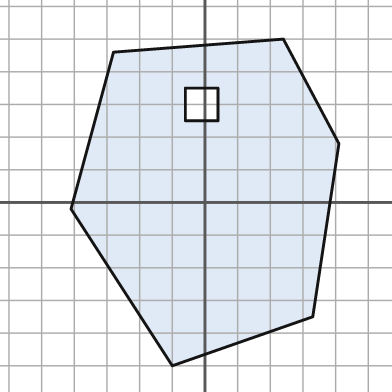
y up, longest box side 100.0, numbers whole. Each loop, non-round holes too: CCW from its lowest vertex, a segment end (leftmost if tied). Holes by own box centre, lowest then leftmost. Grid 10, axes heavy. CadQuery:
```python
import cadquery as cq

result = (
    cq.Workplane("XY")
    .moveTo(-10.0, -50.0)
    .lineTo(33.0, -35.0)
    .lineTo(41.0, 18.0)
    .lineTo(24.0, 50.0)
    .lineTo(-28.0, 46.0)
    .lineTo(-41.0, -2.0)
    .close()
    .moveTo(-6.0, 25.0)
    .lineTo(4.0, 25.0)
    .lineTo(4.0, 35.0)
    .lineTo(-6.0, 35.0)
    .close()
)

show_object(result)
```